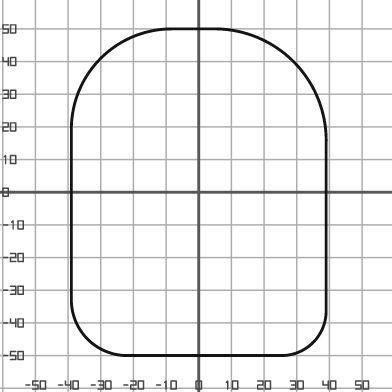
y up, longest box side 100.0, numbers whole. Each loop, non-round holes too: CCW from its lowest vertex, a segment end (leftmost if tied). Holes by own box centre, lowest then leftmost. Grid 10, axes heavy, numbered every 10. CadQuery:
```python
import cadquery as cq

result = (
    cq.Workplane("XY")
    .moveTo(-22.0, -50.0)
    .lineTo(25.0, -50.0)
    .threePointArc((35.0, -46.0), (39.0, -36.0))
    .lineTo(39.0, 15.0)
    .threePointArc((29.0, 40.0), (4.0, 50.0))
    .lineTo(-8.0, 50.0)
    .threePointArc((-30.0, 41.0), (-39.0, 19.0))
    .lineTo(-39.0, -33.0)
    .threePointArc((-34.0, -45.0), (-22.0, -50.0))
    .close()
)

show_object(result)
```